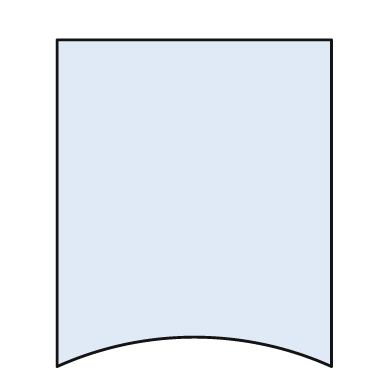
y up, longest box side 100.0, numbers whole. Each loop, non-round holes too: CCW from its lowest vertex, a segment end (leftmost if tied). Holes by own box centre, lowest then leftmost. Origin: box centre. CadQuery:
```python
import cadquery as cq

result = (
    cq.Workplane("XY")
    .moveTo(-42.0, -50.0)
    .threePointArc((0.0, -41.0), (42.0, -50.0))
    .lineTo(42.0, 50.0)
    .lineTo(-42.0, 50.0)
    .close()
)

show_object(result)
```